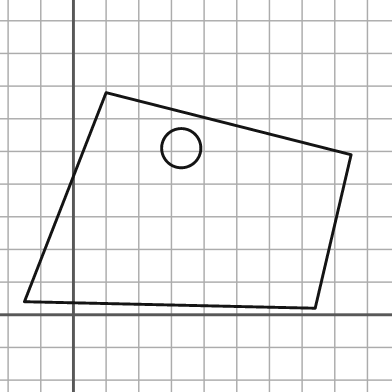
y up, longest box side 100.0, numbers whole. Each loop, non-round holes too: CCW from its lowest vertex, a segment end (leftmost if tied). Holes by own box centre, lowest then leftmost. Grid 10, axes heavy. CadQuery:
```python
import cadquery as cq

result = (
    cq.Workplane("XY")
    .moveTo(74.0, 2.0)
    .lineTo(85.0, 49.0)
    .lineTo(10.0, 68.0)
    .lineTo(-15.0, 4.0)
    .close()
    .moveTo(33.0, 51.0)
    .circle(6.0)
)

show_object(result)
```